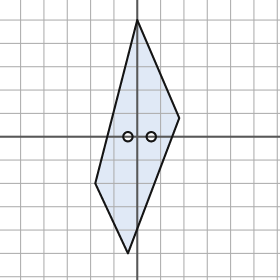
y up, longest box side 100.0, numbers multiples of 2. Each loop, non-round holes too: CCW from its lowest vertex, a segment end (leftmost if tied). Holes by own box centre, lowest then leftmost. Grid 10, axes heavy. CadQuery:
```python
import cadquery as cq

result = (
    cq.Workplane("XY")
    .moveTo(-4.0, -50.0)
    .lineTo(18.0, 8.0)
    .lineTo(0.0, 50.0)
    .lineTo(-18.0, -20.0)
    .close()
    .moveTo(-4.0, 0.0)
    .circle(2.0)
    .moveTo(6.0, 0.0)
    .circle(2.0)
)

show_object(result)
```